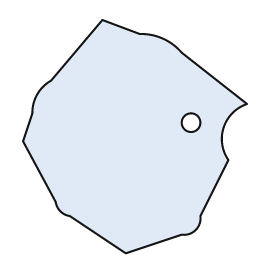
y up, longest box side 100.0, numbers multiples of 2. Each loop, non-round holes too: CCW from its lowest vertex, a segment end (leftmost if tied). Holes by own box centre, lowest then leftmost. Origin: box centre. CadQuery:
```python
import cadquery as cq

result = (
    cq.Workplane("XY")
    .moveTo(-4.0, -50.0)
    .lineTo(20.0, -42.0)
    .threePointArc((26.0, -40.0), (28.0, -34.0))
    .lineTo(40.0, -10.0)
    .threePointArc((38.0, 4.0), (48.0, 14.0))
    .lineTo(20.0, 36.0)
    .threePointArc((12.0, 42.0), (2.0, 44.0))
    .lineTo(-14.0, 50.0)
    .lineTo(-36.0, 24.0)
    .threePointArc((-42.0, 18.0), (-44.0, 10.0))
    .lineTo(-48.0, -2.0)
    .lineTo(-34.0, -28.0)
    .threePointArc((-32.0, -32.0), (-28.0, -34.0))
    .close()
    .moveTo(24.0, 6.0)
    .circle(4.0)
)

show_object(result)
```